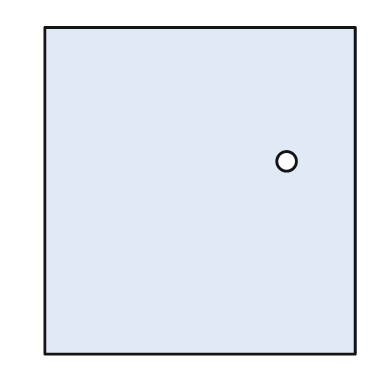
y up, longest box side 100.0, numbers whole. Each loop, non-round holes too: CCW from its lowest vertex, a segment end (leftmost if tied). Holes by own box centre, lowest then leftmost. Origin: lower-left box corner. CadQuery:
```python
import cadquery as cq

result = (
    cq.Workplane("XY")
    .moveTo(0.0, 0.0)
    .lineTo(95.0, 0.0)
    .lineTo(95.0, 100.0)
    .lineTo(0.0, 100.0)
    .close()
    .moveTo(74.0, 59.0)
    .circle(3.0)
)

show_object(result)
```